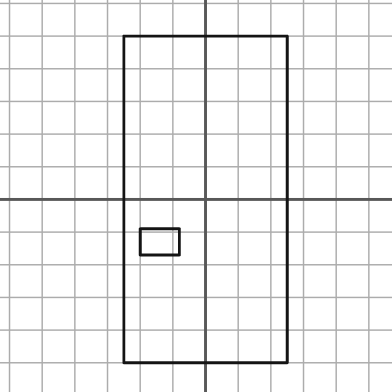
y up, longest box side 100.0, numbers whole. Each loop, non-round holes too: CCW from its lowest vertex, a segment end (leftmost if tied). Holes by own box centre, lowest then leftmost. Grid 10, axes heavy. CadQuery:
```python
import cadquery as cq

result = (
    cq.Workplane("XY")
    .moveTo(-25.0, -50.0)
    .lineTo(25.0, -50.0)
    .lineTo(25.0, 50.0)
    .lineTo(-25.0, 50.0)
    .close()
    .moveTo(-20.0, -17.0)
    .lineTo(-8.0, -17.0)
    .lineTo(-8.0, -9.0)
    .lineTo(-20.0, -9.0)
    .close()
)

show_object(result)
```